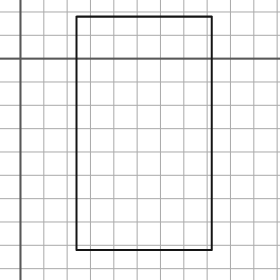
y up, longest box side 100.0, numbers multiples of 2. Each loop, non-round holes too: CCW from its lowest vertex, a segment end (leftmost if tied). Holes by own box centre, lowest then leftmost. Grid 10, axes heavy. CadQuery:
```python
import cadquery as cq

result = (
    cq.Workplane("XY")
    .moveTo(24.0, -82.0)
    .lineTo(82.0, -82.0)
    .lineTo(82.0, 18.0)
    .lineTo(24.0, 18.0)
    .close()
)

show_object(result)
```